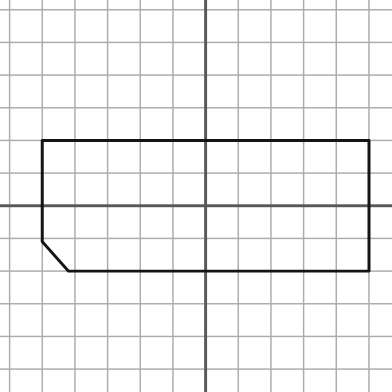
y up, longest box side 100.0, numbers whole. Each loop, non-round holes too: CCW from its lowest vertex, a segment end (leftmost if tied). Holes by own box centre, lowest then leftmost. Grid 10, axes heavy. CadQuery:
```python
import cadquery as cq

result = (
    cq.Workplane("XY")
    .moveTo(-42.0, -20.0)
    .lineTo(50.0, -20.0)
    .lineTo(50.0, 20.0)
    .lineTo(-50.0, 20.0)
    .lineTo(-50.0, -11.0)
    .close()
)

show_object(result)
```